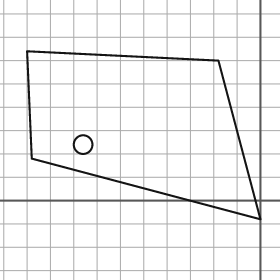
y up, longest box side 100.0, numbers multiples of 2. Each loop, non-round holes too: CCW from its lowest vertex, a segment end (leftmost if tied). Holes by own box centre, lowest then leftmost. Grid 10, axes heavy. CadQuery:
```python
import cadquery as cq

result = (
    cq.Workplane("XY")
    .moveTo(0.0, -8.0)
    .lineTo(-18.0, 60.0)
    .lineTo(-100.0, 64.0)
    .lineTo(-98.0, 18.0)
    .close()
    .moveTo(-76.0, 24.0)
    .circle(4.0)
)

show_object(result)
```